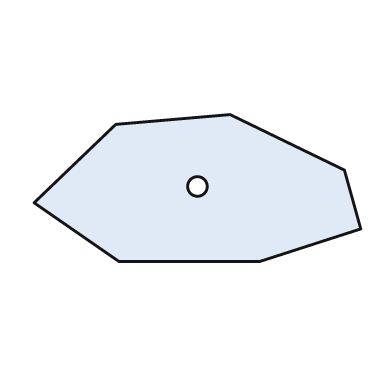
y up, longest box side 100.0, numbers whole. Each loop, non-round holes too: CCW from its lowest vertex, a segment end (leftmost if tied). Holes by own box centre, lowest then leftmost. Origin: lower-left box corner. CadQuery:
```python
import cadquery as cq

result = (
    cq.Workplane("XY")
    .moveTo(26.0, 0.0)
    .lineTo(69.0, 0.0)
    .lineTo(100.0, 10.0)
    .lineTo(95.0, 28.0)
    .lineTo(60.0, 45.0)
    .lineTo(25.0, 42.0)
    .lineTo(0.0, 18.0)
    .close()
    .moveTo(50.0, 23.0)
    .circle(3.0)
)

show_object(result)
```